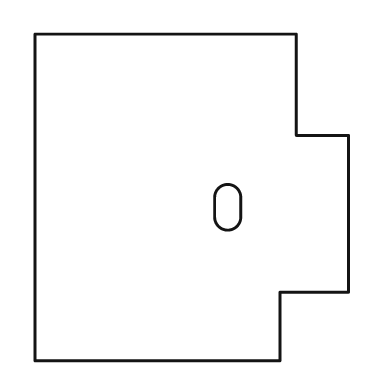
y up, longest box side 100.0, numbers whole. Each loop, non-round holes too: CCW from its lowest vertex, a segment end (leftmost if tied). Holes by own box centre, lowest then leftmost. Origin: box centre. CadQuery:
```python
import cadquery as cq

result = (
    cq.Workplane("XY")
    .moveTo(-48.0, -50.0)
    .lineTo(27.0, -50.0)
    .lineTo(27.0, -29.0)
    .lineTo(48.0, -29.0)
    .lineTo(48.0, 19.0)
    .lineTo(32.0, 19.0)
    .lineTo(32.0, 50.0)
    .lineTo(-48.0, 50.0)
    .close()
    .moveTo(7.0, -6.0)
    .threePointArc((11.0, -10.0), (15.0, -6.0))
    .lineTo(15.0, 0.0)
    .threePointArc((11.0, 4.0), (7.0, 0.0))
    .close()
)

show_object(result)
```